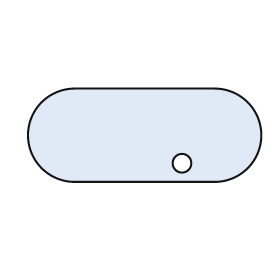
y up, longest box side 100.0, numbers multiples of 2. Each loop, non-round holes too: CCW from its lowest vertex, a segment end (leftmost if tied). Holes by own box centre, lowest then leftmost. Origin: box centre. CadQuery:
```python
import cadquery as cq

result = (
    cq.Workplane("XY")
    .moveTo(-30.0, -20.0)
    .lineTo(30.0, -20.0)
    .threePointArc((50.0, 0.0), (30.0, 20.0))
    .lineTo(-30.0, 20.0)
    .threePointArc((-50.0, 0.0), (-30.0, -20.0))
    .close()
    .moveTo(16.0, -12.0)
    .circle(4.0)
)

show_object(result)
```